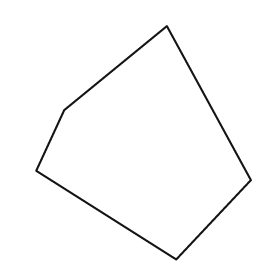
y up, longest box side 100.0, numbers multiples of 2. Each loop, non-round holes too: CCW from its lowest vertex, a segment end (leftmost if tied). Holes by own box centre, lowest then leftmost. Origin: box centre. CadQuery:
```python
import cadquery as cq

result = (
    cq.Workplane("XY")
    .moveTo(14.0, -50.0)
    .lineTo(46.0, -16.0)
    .lineTo(10.0, 50.0)
    .lineTo(-34.0, 14.0)
    .lineTo(-46.0, -12.0)
    .close()
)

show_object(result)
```